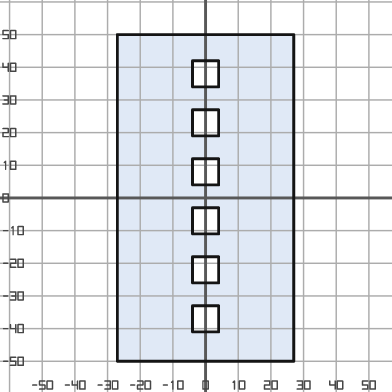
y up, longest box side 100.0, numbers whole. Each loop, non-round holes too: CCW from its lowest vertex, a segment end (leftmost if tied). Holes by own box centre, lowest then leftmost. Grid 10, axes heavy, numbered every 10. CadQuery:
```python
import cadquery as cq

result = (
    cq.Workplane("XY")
    .moveTo(-27.0, -50.0)
    .lineTo(27.0, -50.0)
    .lineTo(27.0, 50.0)
    .lineTo(-27.0, 50.0)
    .close()
    .moveTo(-4.0, -41.0)
    .lineTo(4.0, -41.0)
    .lineTo(4.0, -33.0)
    .lineTo(-4.0, -33.0)
    .close()
    .moveTo(-4.0, -26.0)
    .lineTo(4.0, -26.0)
    .lineTo(4.0, -18.0)
    .lineTo(-4.0, -18.0)
    .close()
    .moveTo(-4.0, -11.0)
    .lineTo(4.0, -11.0)
    .lineTo(4.0, -3.0)
    .lineTo(-4.0, -3.0)
    .close()
    .moveTo(-4.0, 4.0)
    .lineTo(4.0, 4.0)
    .lineTo(4.0, 12.0)
    .lineTo(-4.0, 12.0)
    .close()
    .moveTo(-4.0, 19.0)
    .lineTo(4.0, 19.0)
    .lineTo(4.0, 27.0)
    .lineTo(-4.0, 27.0)
    .close()
    .moveTo(-4.0, 34.0)
    .lineTo(4.0, 34.0)
    .lineTo(4.0, 42.0)
    .lineTo(-4.0, 42.0)
    .close()
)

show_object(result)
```